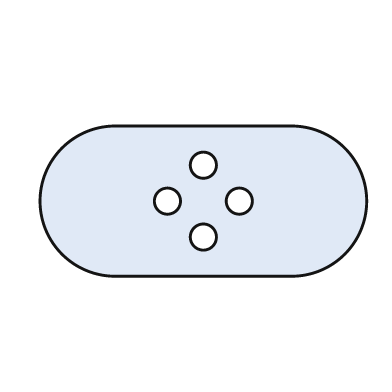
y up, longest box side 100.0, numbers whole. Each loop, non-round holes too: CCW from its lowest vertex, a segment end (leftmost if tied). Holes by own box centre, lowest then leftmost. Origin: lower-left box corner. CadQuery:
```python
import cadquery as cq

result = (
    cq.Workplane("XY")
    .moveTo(23.0, 0.0)
    .lineTo(77.0, 0.0)
    .threePointArc((100.0, 23.0), (77.0, 46.0))
    .lineTo(23.0, 46.0)
    .threePointArc((0.0, 23.0), (23.0, 0.0))
    .close()
    .moveTo(50.0, 12.0)
    .circle(4.0)
    .moveTo(39.0, 23.0)
    .circle(4.0)
    .moveTo(61.0, 23.0)
    .circle(4.0)
    .moveTo(50.0, 34.0)
    .circle(4.0)
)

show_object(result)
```